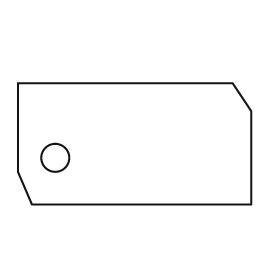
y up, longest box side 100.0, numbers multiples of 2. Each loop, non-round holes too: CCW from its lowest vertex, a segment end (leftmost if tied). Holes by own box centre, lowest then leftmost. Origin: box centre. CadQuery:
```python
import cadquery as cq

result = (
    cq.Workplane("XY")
    .moveTo(-44.0, -26.0)
    .lineTo(50.0, -26.0)
    .lineTo(50.0, 14.0)
    .lineTo(42.0, 26.0)
    .lineTo(-50.0, 26.0)
    .lineTo(-50.0, -12.0)
    .close()
    .moveTo(-34.0, -6.0)
    .circle(6.0)
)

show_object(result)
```